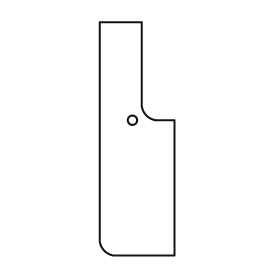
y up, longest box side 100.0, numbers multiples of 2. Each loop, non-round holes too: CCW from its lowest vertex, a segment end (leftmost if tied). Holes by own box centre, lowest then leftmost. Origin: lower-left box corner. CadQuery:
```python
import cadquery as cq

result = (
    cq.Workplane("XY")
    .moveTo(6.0, 0.0)
    .lineTo(32.0, 0.0)
    .lineTo(32.0, 58.0)
    .lineTo(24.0, 58.0)
    .threePointArc((20.0, 60.0), (18.0, 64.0))
    .lineTo(18.0, 100.0)
    .lineTo(0.0, 100.0)
    .lineTo(0.0, 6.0)
    .threePointArc((2.0, 2.0), (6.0, 0.0))
    .close()
    .moveTo(14.0, 58.0)
    .circle(2.0)
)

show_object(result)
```